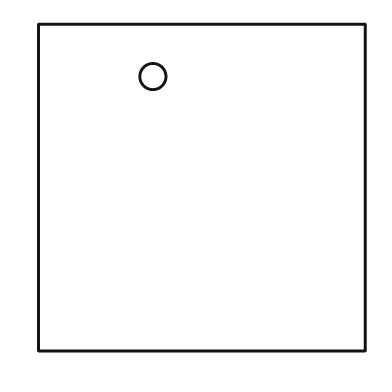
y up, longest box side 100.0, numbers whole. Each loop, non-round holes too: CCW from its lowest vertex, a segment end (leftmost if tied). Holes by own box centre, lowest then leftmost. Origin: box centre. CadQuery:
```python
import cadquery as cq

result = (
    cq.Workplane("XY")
    .moveTo(-50.0, -50.0)
    .lineTo(50.0, -50.0)
    .lineTo(50.0, 50.0)
    .lineTo(-50.0, 50.0)
    .close()
    .moveTo(-15.0, 34.0)
    .circle(4.0)
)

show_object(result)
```